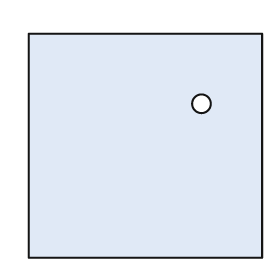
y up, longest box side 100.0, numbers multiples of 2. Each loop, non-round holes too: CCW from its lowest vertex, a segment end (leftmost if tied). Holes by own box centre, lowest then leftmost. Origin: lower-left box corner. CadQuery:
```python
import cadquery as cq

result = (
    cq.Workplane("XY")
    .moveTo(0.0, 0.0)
    .lineTo(100.0, 0.0)
    .lineTo(100.0, 96.0)
    .lineTo(0.0, 96.0)
    .close()
    .moveTo(74.0, 66.0)
    .circle(4.0)
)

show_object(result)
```